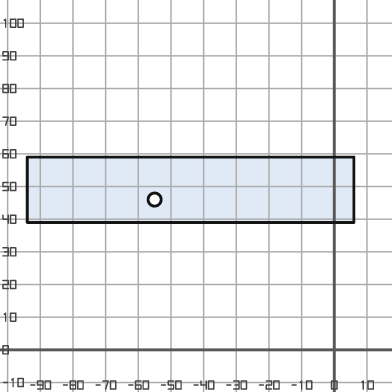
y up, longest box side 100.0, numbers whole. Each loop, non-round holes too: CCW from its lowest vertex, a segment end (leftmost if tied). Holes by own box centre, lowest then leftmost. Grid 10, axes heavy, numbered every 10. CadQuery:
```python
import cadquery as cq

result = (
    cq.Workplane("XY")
    .moveTo(-94.0, 39.0)
    .lineTo(6.0, 39.0)
    .lineTo(6.0, 59.0)
    .lineTo(-94.0, 59.0)
    .close()
    .moveTo(-55.0, 46.0)
    .circle(2.0)
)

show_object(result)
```